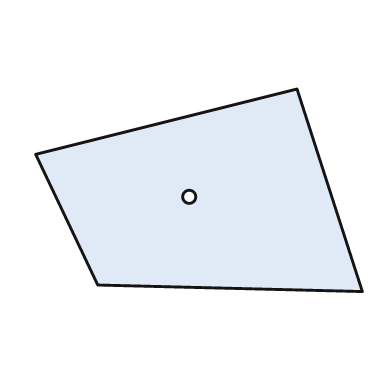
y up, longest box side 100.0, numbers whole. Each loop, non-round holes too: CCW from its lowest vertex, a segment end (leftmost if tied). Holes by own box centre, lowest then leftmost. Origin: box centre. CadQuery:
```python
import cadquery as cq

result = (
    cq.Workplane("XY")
    .moveTo(50.0, -31.0)
    .lineTo(30.0, 31.0)
    .lineTo(-50.0, 11.0)
    .lineTo(-31.0, -29.0)
    .close()
    .moveTo(-3.0, -2.0)
    .circle(2.0)
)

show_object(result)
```